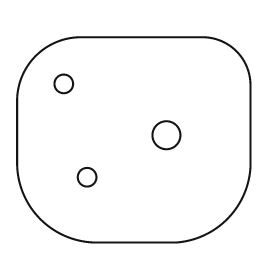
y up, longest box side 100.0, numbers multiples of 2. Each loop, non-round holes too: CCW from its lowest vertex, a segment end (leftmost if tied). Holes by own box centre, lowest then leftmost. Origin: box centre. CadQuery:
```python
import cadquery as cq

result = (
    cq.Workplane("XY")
    .moveTo(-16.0, -44.0)
    .lineTo(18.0, -44.0)
    .threePointArc((40.0, -34.0), (50.0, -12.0))
    .lineTo(50.0, 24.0)
    .threePointArc((44.0, 38.0), (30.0, 44.0))
    .lineTo(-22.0, 44.0)
    .threePointArc((-42.0, 36.0), (-50.0, 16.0))
    .lineTo(-50.0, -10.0)
    .threePointArc((-40.0, -34.0), (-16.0, -44.0))
    .close()
    .moveTo(-20.0, -16.0)
    .circle(4.0)
    .moveTo(14.0, 2.0)
    .circle(6.0)
    .moveTo(-30.0, 24.0)
    .circle(4.0)
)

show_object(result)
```